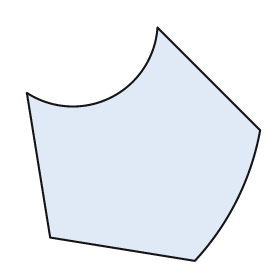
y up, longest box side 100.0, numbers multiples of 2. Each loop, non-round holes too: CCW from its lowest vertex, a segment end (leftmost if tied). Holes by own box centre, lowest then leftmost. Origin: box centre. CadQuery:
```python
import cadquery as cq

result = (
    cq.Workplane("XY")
    .moveTo(22.0, -50.0)
    .threePointArc((40.0, -24.0), (50.0, 6.0))
    .lineTo(6.0, 50.0)
    .threePointArc((-14.0, 20.0), (-50.0, 22.0))
    .lineTo(-40.0, -40.0)
    .close()
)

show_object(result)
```